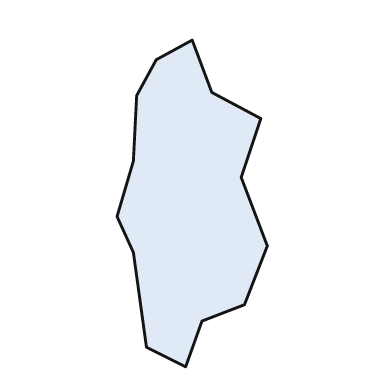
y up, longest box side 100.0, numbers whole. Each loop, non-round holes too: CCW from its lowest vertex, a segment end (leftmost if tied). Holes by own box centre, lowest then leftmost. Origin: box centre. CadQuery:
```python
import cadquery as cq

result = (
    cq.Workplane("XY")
    .moveTo(-2.0, -50.0)
    .lineTo(3.0, -36.0)
    .lineTo(16.0, -31.0)
    .lineTo(23.0, -13.0)
    .lineTo(15.0, 8.0)
    .lineTo(21.0, 26.0)
    .lineTo(6.0, 34.0)
    .lineTo(0.0, 50.0)
    .lineTo(-11.0, 44.0)
    .lineTo(-17.0, 33.0)
    .lineTo(-18.0, 13.0)
    .lineTo(-23.0, -4.0)
    .lineTo(-18.0, -15.0)
    .lineTo(-14.0, -44.0)
    .close()
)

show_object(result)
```